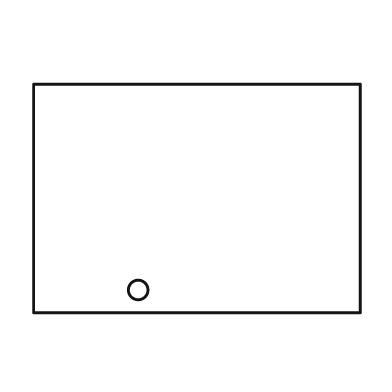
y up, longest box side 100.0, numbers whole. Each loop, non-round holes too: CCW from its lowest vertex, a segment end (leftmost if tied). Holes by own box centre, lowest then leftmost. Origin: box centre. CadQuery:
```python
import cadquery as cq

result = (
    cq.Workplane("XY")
    .moveTo(-50.0, -35.0)
    .lineTo(50.0, -35.0)
    .lineTo(50.0, 35.0)
    .lineTo(-50.0, 35.0)
    .close()
    .moveTo(-18.0, -28.0)
    .circle(3.0)
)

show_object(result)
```